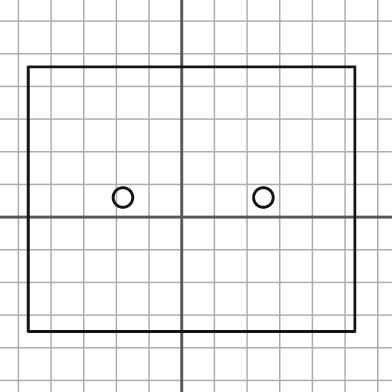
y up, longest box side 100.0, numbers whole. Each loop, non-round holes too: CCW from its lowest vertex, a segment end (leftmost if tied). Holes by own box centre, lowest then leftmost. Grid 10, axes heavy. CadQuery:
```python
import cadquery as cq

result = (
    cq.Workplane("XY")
    .moveTo(-47.0, -35.0)
    .lineTo(53.0, -35.0)
    .lineTo(53.0, 46.0)
    .lineTo(-47.0, 46.0)
    .close()
    .moveTo(-18.0, 6.0)
    .circle(3.0)
    .moveTo(25.0, 6.0)
    .circle(3.0)
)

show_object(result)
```